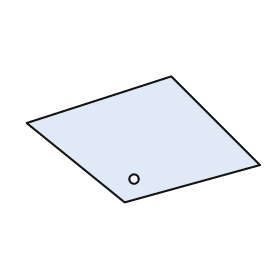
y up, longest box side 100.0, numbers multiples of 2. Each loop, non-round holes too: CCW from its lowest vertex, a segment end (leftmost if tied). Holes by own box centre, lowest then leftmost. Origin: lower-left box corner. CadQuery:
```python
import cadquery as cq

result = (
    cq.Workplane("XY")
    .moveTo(42.0, 0.0)
    .lineTo(100.0, 16.0)
    .lineTo(62.0, 54.0)
    .lineTo(0.0, 34.0)
    .close()
    .moveTo(46.0, 10.0)
    .circle(2.0)
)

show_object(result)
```